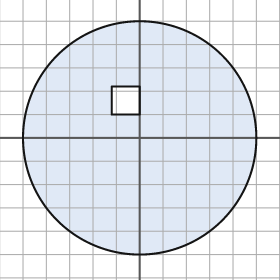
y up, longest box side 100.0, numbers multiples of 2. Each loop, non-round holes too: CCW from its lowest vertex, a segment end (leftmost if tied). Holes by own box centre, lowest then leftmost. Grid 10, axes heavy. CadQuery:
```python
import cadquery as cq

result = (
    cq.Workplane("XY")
    .moveTo(0.0, 0.0)
    .circle(50.0)
    .moveTo(-12.0, 10.0)
    .lineTo(0.0, 10.0)
    .lineTo(0.0, 22.0)
    .lineTo(-12.0, 22.0)
    .close()
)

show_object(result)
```